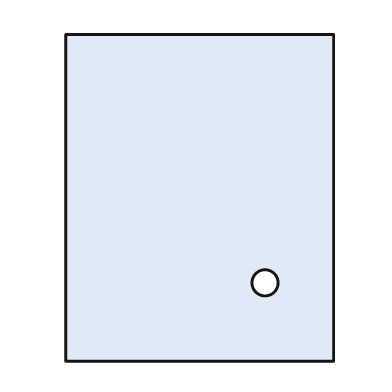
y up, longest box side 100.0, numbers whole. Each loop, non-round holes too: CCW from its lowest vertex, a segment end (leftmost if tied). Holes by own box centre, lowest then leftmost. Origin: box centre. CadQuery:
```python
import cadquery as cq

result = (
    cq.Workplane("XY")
    .moveTo(-41.0, -50.0)
    .lineTo(41.0, -50.0)
    .lineTo(41.0, 50.0)
    .lineTo(-41.0, 50.0)
    .close()
    .moveTo(20.0, -26.0)
    .circle(4.0)
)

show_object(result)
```